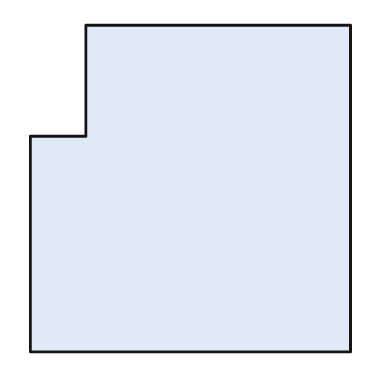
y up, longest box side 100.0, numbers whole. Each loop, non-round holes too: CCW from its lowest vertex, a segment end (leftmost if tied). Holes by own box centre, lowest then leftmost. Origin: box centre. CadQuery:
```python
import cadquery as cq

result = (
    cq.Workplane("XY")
    .moveTo(-49.0, -50.0)
    .lineTo(49.0, -50.0)
    .lineTo(49.0, 50.0)
    .lineTo(-32.0, 50.0)
    .lineTo(-32.0, 16.0)
    .lineTo(-49.0, 16.0)
    .close()
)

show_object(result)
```